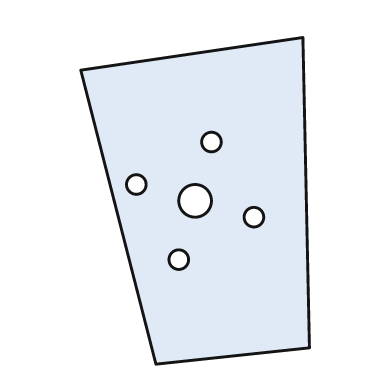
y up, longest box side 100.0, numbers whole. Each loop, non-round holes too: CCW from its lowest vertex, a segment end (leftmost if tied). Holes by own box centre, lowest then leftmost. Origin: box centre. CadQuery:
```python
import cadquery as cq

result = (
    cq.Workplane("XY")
    .moveTo(-12.0, -50.0)
    .lineTo(35.0, -45.0)
    .lineTo(33.0, 50.0)
    .lineTo(-35.0, 40.0)
    .close()
    .moveTo(-5.0, -18.0)
    .circle(3.0)
    .moveTo(18.0, -5.0)
    .circle(3.0)
    .moveTo(0.0, 0.0)
    .circle(5.0)
    .moveTo(-18.0, 5.0)
    .circle(3.0)
    .moveTo(5.0, 18.0)
    .circle(3.0)
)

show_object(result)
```